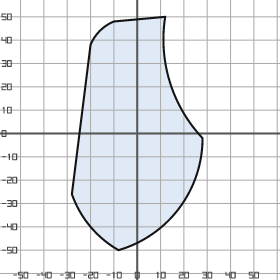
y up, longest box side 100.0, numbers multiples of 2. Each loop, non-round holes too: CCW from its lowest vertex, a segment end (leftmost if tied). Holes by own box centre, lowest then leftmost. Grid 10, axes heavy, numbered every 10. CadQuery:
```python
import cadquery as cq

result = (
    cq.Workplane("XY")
    .moveTo(-8.0, -50.0)
    .threePointArc((18.0, -32.0), (28.0, -2.0))
    .threePointArc((14.0, 22.0), (12.0, 50.0))
    .lineTo(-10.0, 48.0)
    .threePointArc((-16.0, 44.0), (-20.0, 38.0))
    .lineTo(-28.0, -26.0)
    .threePointArc((-20.0, -40.0), (-8.0, -50.0))
    .close()
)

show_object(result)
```